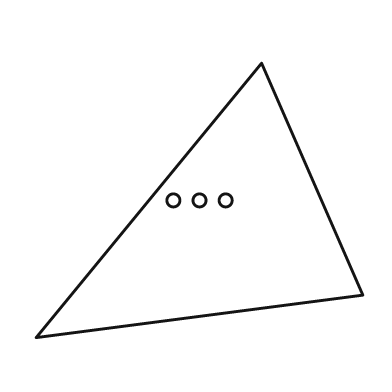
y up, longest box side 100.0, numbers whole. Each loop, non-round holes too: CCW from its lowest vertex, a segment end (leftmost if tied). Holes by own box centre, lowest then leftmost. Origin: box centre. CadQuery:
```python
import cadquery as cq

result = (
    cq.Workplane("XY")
    .moveTo(-50.0, -42.0)
    .lineTo(50.0, -29.0)
    .lineTo(19.0, 42.0)
    .close()
    .moveTo(-8.0, 0.0)
    .circle(2.0)
    .moveTo(0.0, 0.0)
    .circle(2.0)
    .moveTo(8.0, 0.0)
    .circle(2.0)
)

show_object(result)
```